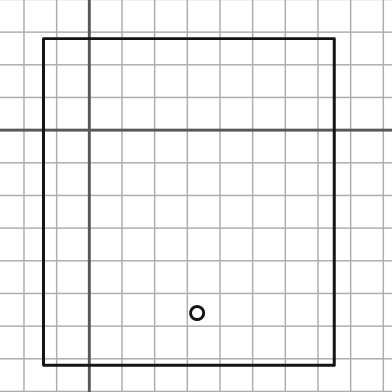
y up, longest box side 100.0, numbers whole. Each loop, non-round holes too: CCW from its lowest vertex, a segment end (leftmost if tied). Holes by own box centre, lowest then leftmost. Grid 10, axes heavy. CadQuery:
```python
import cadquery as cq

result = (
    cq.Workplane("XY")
    .moveTo(-14.0, -72.0)
    .lineTo(75.0, -72.0)
    .lineTo(75.0, 28.0)
    .lineTo(-14.0, 28.0)
    .close()
    .moveTo(33.0, -56.0)
    .circle(2.0)
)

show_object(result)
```